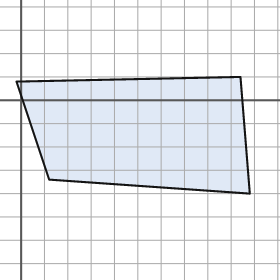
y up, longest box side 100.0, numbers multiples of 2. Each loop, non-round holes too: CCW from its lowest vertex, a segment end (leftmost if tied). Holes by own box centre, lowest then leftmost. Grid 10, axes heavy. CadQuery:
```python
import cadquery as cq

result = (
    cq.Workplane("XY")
    .moveTo(98.0, -40.0)
    .lineTo(94.0, 10.0)
    .lineTo(-2.0, 8.0)
    .lineTo(12.0, -34.0)
    .close()
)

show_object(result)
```